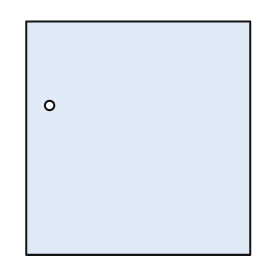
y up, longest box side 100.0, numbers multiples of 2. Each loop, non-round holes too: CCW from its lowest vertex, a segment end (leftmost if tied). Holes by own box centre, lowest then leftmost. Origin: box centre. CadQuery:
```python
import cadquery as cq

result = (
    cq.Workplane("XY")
    .moveTo(-48.0, -50.0)
    .lineTo(48.0, -50.0)
    .lineTo(48.0, 50.0)
    .lineTo(-48.0, 50.0)
    .close()
    .moveTo(-38.0, 14.0)
    .circle(2.0)
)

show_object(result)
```